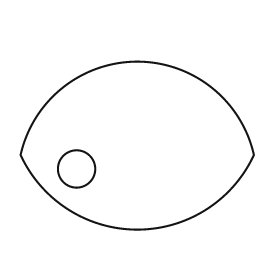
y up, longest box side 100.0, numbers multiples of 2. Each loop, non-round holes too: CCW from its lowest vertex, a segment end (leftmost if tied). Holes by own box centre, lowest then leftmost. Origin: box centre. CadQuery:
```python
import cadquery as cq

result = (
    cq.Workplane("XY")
    .moveTo(-50.0, -4.0)
    .threePointArc((0.0, -36.0), (50.0, -4.0))
    .threePointArc((0.0, 36.0), (-50.0, -4.0))
    .close()
    .moveTo(-26.0, -10.0)
    .circle(8.0)
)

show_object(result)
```